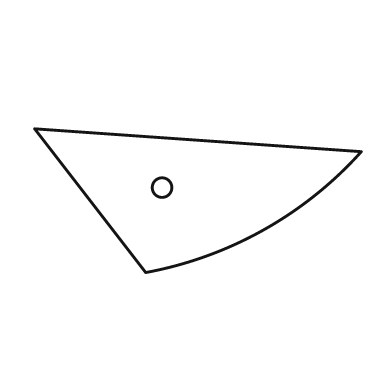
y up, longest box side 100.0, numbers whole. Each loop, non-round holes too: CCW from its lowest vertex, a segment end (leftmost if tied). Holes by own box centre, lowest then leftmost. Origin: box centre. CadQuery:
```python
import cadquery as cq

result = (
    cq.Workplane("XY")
    .moveTo(-16.0, -22.0)
    .threePointArc((20.0, -9.0), (50.0, 15.0))
    .lineTo(-50.0, 22.0)
    .close()
    .moveTo(-11.0, 4.0)
    .circle(3.0)
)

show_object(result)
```